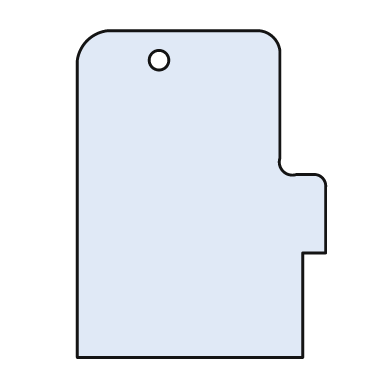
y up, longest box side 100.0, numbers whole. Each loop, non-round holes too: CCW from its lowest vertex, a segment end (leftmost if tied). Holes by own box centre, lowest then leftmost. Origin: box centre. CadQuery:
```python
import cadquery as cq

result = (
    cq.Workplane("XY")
    .moveTo(-38.0, -50.0)
    .lineTo(31.0, -50.0)
    .lineTo(31.0, -18.0)
    .lineTo(38.0, -18.0)
    .lineTo(38.0, 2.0)
    .threePointArc((37.0, 5.0), (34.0, 6.0))
    .lineTo(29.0, 6.0)
    .threePointArc((25.0, 7.0), (24.0, 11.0))
    .lineTo(24.0, 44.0)
    .threePointArc((22.0, 48.0), (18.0, 50.0))
    .lineTo(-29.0, 50.0)
    .threePointArc((-35.0, 47.0), (-38.0, 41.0))
    .close()
    .moveTo(-13.0, 41.0)
    .circle(3.0)
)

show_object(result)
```